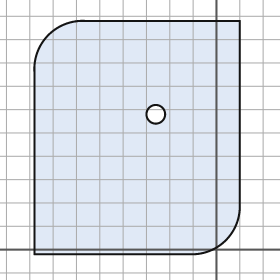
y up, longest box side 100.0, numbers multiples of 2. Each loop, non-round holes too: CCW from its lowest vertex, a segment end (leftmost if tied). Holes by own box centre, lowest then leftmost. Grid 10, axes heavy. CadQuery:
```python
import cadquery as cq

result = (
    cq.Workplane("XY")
    .moveTo(-78.0, -2.0)
    .lineTo(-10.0, -2.0)
    .threePointArc((4.0, 4.0), (10.0, 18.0))
    .lineTo(10.0, 98.0)
    .lineTo(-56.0, 98.0)
    .threePointArc((-72.0, 92.0), (-78.0, 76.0))
    .close()
    .moveTo(-26.0, 58.0)
    .circle(4.0)
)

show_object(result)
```